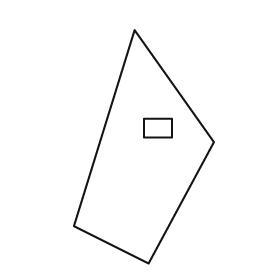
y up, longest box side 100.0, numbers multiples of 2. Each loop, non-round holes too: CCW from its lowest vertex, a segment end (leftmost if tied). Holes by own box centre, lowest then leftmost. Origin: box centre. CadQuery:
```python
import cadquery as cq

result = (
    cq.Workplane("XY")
    .moveTo(2.0, -50.0)
    .lineTo(30.0, 2.0)
    .lineTo(-4.0, 50.0)
    .lineTo(-30.0, -34.0)
    .close()
    .moveTo(0.0, 4.0)
    .lineTo(12.0, 4.0)
    .lineTo(12.0, 12.0)
    .lineTo(0.0, 12.0)
    .close()
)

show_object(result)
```